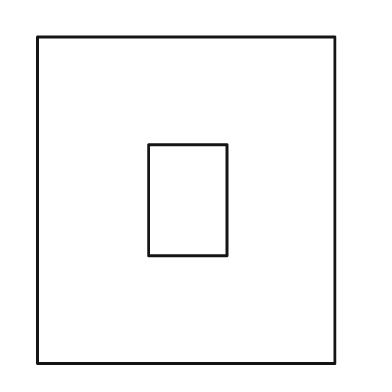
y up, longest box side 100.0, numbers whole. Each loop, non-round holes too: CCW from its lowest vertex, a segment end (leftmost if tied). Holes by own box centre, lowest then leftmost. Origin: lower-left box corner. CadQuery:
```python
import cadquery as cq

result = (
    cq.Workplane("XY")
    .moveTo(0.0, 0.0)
    .lineTo(91.0, 0.0)
    .lineTo(91.0, 100.0)
    .lineTo(0.0, 100.0)
    .close()
    .moveTo(34.0, 33.0)
    .lineTo(58.0, 33.0)
    .lineTo(58.0, 67.0)
    .lineTo(34.0, 67.0)
    .close()
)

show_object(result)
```